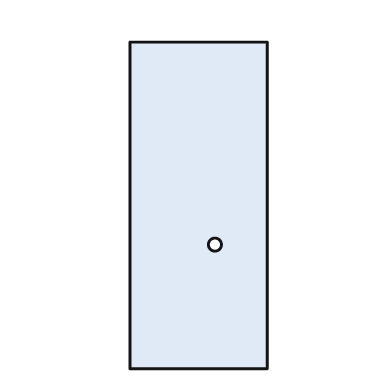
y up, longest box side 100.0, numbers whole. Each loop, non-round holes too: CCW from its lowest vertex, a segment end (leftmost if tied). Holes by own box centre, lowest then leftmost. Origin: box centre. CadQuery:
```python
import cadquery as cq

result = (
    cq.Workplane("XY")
    .moveTo(-21.0, -50.0)
    .lineTo(21.0, -50.0)
    .lineTo(21.0, 50.0)
    .lineTo(-21.0, 50.0)
    .close()
    .moveTo(5.0, -12.0)
    .circle(2.0)
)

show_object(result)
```